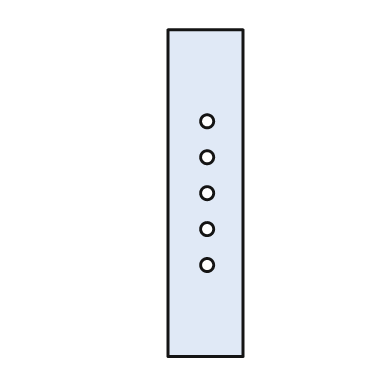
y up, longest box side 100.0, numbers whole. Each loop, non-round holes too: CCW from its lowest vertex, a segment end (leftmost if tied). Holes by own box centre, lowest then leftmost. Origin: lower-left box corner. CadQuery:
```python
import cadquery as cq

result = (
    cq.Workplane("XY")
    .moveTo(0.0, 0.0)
    .lineTo(23.0, 0.0)
    .lineTo(23.0, 100.0)
    .lineTo(0.0, 100.0)
    .close()
    .moveTo(12.0, 28.0)
    .circle(2.0)
    .moveTo(12.0, 39.0)
    .circle(2.0)
    .moveTo(12.0, 50.0)
    .circle(2.0)
    .moveTo(12.0, 61.0)
    .circle(2.0)
    .moveTo(12.0, 72.0)
    .circle(2.0)
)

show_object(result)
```